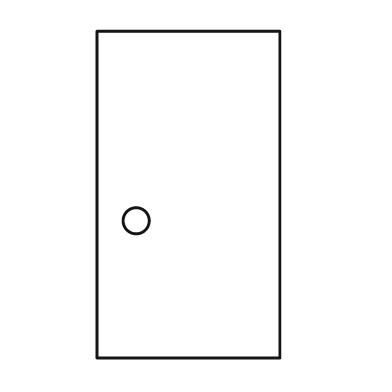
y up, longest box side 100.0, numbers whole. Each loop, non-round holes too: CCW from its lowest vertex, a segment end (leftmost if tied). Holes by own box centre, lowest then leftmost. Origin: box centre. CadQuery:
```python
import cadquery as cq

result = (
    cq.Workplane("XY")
    .moveTo(-28.0, -50.0)
    .lineTo(28.0, -50.0)
    .lineTo(28.0, 50.0)
    .lineTo(-28.0, 50.0)
    .close()
    .moveTo(-16.0, -8.0)
    .circle(4.0)
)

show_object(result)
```